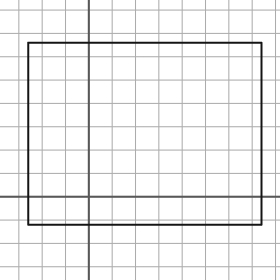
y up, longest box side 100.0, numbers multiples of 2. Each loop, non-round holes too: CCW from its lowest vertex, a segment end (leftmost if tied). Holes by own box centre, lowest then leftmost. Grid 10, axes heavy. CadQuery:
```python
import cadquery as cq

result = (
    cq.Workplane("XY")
    .moveTo(-26.0, -12.0)
    .lineTo(74.0, -12.0)
    .lineTo(74.0, 66.0)
    .lineTo(-26.0, 66.0)
    .close()
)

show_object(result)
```